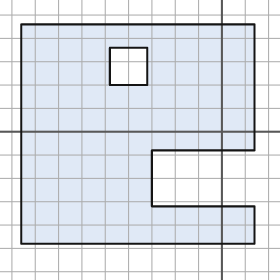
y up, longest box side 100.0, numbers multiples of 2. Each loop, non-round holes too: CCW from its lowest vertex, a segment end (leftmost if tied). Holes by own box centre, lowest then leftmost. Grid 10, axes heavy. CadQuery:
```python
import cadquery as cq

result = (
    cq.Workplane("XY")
    .moveTo(-86.0, -48.0)
    .lineTo(14.0, -48.0)
    .lineTo(14.0, -32.0)
    .lineTo(-30.0, -32.0)
    .lineTo(-30.0, -8.0)
    .lineTo(14.0, -8.0)
    .lineTo(14.0, 46.0)
    .lineTo(-86.0, 46.0)
    .close()
    .moveTo(-48.0, 20.0)
    .lineTo(-32.0, 20.0)
    .lineTo(-32.0, 36.0)
    .lineTo(-48.0, 36.0)
    .close()
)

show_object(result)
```